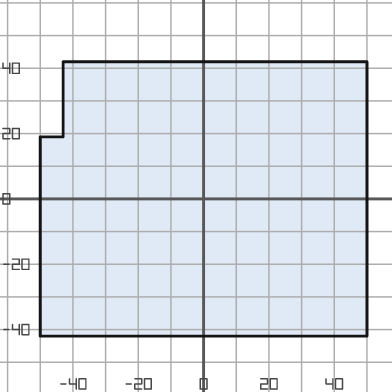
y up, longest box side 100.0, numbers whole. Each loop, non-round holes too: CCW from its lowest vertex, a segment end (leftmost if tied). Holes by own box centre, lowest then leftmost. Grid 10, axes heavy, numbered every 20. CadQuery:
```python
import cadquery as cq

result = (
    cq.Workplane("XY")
    .moveTo(-50.0, -42.0)
    .lineTo(50.0, -42.0)
    .lineTo(50.0, 42.0)
    .lineTo(-43.0, 42.0)
    .lineTo(-43.0, 19.0)
    .lineTo(-50.0, 19.0)
    .close()
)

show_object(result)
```